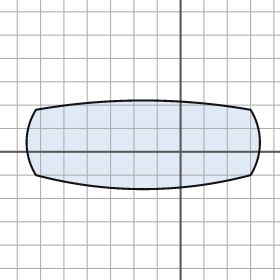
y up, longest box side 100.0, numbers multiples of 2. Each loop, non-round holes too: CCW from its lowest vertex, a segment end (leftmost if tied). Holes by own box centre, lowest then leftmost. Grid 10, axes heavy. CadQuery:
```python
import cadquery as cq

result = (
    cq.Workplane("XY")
    .moveTo(-62.0, -10.0)
    .threePointArc((-16.0, -16.0), (30.0, -10.0))
    .threePointArc((34.0, 4.0), (30.0, 18.0))
    .threePointArc((-16.0, 22.0), (-62.0, 18.0))
    .threePointArc((-66.0, 4.0), (-62.0, -10.0))
    .close()
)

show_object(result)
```